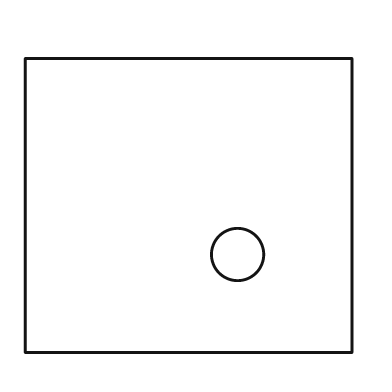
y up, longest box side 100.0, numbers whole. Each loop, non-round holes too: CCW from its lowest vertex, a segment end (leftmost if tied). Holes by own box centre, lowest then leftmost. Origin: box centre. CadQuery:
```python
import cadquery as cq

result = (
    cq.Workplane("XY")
    .moveTo(-50.0, -45.0)
    .lineTo(50.0, -45.0)
    .lineTo(50.0, 45.0)
    .lineTo(-50.0, 45.0)
    .close()
    .moveTo(15.0, -15.0)
    .circle(8.0)
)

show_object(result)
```